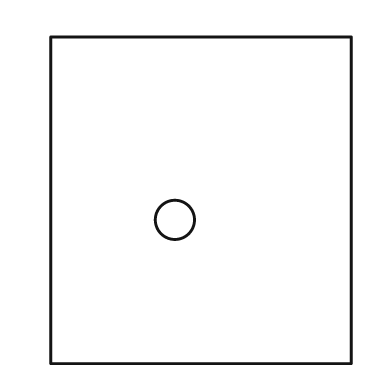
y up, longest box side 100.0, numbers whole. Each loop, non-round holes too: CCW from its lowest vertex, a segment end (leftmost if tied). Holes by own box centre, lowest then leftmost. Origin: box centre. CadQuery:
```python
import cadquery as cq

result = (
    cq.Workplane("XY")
    .moveTo(-46.0, -50.0)
    .lineTo(46.0, -50.0)
    .lineTo(46.0, 50.0)
    .lineTo(-46.0, 50.0)
    .close()
    .moveTo(-8.0, -6.0)
    .circle(6.0)
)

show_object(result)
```